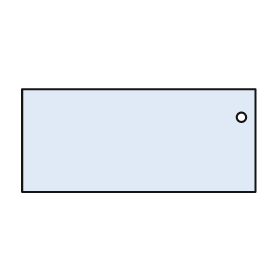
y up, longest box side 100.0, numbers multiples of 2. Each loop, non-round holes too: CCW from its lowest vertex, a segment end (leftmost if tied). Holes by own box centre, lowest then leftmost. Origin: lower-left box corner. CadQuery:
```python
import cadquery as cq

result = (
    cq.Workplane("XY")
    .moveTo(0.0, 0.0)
    .lineTo(100.0, 0.0)
    .lineTo(100.0, 44.0)
    .lineTo(0.0, 44.0)
    .close()
    .moveTo(94.0, 32.0)
    .circle(2.0)
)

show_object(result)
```